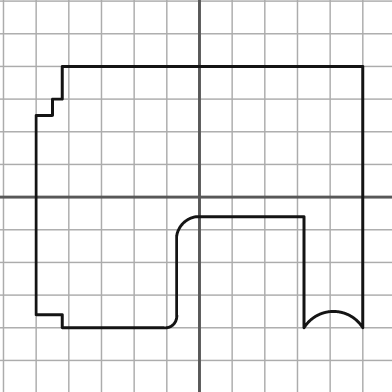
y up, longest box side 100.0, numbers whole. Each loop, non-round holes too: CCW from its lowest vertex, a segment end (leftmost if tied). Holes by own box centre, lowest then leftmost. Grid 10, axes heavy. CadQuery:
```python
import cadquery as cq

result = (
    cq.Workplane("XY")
    .moveTo(-42.0, -40.0)
    .lineTo(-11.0, -40.0)
    .threePointArc((-8.0, -39.0), (-7.0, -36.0))
    .lineTo(-7.0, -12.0)
    .threePointArc((-5.0, -8.0), (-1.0, -6.0))
    .lineTo(32.0, -6.0)
    .lineTo(32.0, -40.0)
    .threePointArc((41.0, -35.0), (50.0, -40.0))
    .lineTo(50.0, 40.0)
    .lineTo(-42.0, 40.0)
    .lineTo(-42.0, 30.0)
    .lineTo(-45.0, 30.0)
    .lineTo(-45.0, 25.0)
    .lineTo(-50.0, 25.0)
    .lineTo(-50.0, -36.0)
    .lineTo(-42.0, -36.0)
    .close()
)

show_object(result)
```